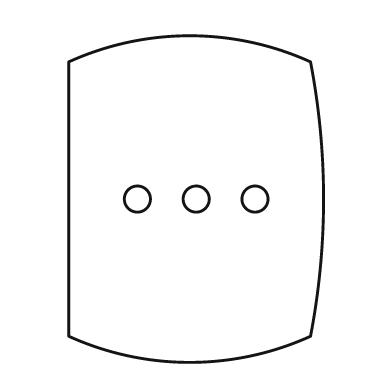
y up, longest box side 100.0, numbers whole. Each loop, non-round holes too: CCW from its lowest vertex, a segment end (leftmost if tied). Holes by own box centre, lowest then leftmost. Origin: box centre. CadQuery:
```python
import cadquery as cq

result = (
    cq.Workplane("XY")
    .moveTo(-39.0, -42.0)
    .threePointArc((-2.0, -50.0), (35.0, -42.0))
    .threePointArc((39.0, 0.0), (35.0, 42.0))
    .threePointArc((-2.0, 50.0), (-39.0, 42.0))
    .close()
    .moveTo(-18.0, 0.0)
    .circle(4.0)
    .moveTo(0.0, 0.0)
    .circle(4.0)
    .moveTo(18.0, 0.0)
    .circle(4.0)
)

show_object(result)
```